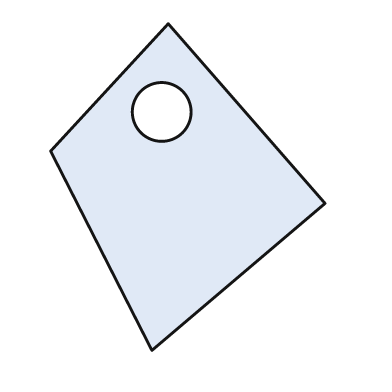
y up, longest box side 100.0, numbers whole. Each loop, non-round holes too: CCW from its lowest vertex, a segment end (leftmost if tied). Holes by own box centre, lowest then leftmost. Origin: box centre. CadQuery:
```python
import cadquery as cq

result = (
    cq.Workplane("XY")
    .moveTo(-11.0, -50.0)
    .lineTo(42.0, -5.0)
    .lineTo(-6.0, 50.0)
    .lineTo(-42.0, 11.0)
    .close()
    .moveTo(-8.0, 23.0)
    .circle(9.0)
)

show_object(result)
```